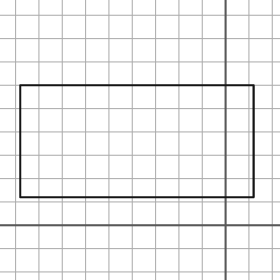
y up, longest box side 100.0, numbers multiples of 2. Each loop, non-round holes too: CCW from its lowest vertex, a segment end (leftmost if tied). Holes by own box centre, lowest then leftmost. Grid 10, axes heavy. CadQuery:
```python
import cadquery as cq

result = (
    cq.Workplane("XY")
    .moveTo(-88.0, 12.0)
    .lineTo(12.0, 12.0)
    .lineTo(12.0, 60.0)
    .lineTo(-88.0, 60.0)
    .close()
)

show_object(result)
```